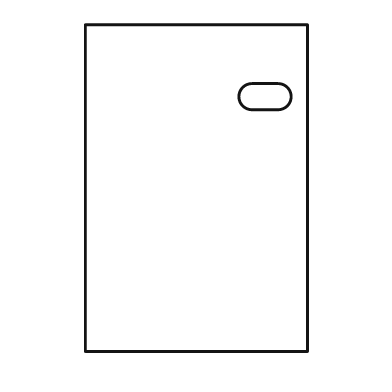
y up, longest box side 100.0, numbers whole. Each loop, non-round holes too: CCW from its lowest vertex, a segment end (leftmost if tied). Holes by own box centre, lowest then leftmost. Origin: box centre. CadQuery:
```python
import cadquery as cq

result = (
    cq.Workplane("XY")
    .moveTo(-34.0, -50.0)
    .lineTo(34.0, -50.0)
    .lineTo(34.0, 50.0)
    .lineTo(-34.0, 50.0)
    .close()
    .moveTo(17.0, 24.0)
    .lineTo(25.0, 24.0)
    .threePointArc((29.0, 28.0), (25.0, 32.0))
    .lineTo(17.0, 32.0)
    .threePointArc((13.0, 28.0), (17.0, 24.0))
    .close()
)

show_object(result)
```